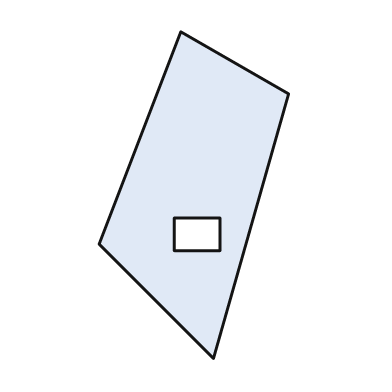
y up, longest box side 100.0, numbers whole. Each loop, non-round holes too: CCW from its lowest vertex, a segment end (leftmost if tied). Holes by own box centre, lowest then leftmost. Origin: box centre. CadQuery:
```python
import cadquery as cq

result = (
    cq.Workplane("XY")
    .moveTo(6.0, -50.0)
    .lineTo(29.0, 31.0)
    .lineTo(-4.0, 50.0)
    .lineTo(-29.0, -15.0)
    .close()
    .moveTo(-6.0, -17.0)
    .lineTo(8.0, -17.0)
    .lineTo(8.0, -7.0)
    .lineTo(-6.0, -7.0)
    .close()
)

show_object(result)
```